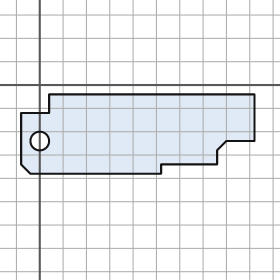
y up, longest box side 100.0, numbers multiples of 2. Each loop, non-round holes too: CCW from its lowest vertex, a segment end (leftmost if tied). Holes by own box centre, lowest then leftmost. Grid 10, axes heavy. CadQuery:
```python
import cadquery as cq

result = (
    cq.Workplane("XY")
    .moveTo(-4.0, -38.0)
    .lineTo(52.0, -38.0)
    .lineTo(52.0, -34.0)
    .lineTo(76.0, -34.0)
    .lineTo(76.0, -28.0)
    .lineTo(80.0, -24.0)
    .lineTo(92.0, -24.0)
    .lineTo(92.0, -4.0)
    .lineTo(4.0, -4.0)
    .lineTo(4.0, -12.0)
    .lineTo(-8.0, -12.0)
    .lineTo(-8.0, -34.0)
    .close()
    .moveTo(0.0, -24.0)
    .circle(4.0)
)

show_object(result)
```